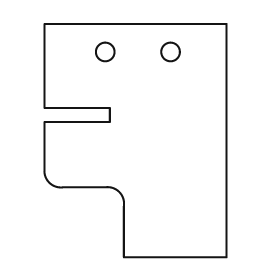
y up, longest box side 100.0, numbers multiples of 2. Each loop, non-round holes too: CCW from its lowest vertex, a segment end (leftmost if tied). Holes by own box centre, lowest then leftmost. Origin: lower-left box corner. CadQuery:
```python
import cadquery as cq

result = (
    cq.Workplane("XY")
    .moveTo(34.0, 0.0)
    .lineTo(78.0, 0.0)
    .lineTo(78.0, 100.0)
    .lineTo(0.0, 100.0)
    .lineTo(0.0, 64.0)
    .lineTo(28.0, 64.0)
    .lineTo(28.0, 58.0)
    .lineTo(0.0, 58.0)
    .lineTo(0.0, 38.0)
    .threePointArc((2.0, 32.0), (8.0, 30.0))
    .lineTo(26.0, 30.0)
    .threePointArc((32.0, 28.0), (34.0, 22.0))
    .close()
    .moveTo(26.0, 88.0)
    .circle(4.0)
    .moveTo(54.0, 88.0)
    .circle(4.0)
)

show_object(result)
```